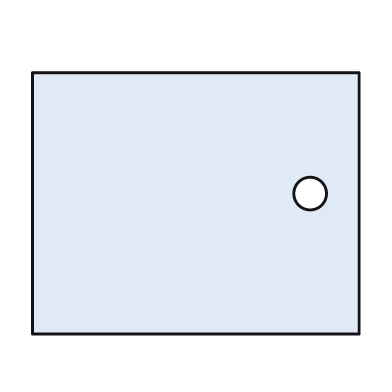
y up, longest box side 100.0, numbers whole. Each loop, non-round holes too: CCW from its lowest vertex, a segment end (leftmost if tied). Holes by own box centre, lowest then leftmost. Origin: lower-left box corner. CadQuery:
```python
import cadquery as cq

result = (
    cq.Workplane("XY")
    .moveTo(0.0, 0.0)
    .lineTo(100.0, 0.0)
    .lineTo(100.0, 80.0)
    .lineTo(0.0, 80.0)
    .close()
    .moveTo(85.0, 43.0)
    .circle(5.0)
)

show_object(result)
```